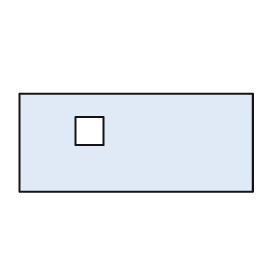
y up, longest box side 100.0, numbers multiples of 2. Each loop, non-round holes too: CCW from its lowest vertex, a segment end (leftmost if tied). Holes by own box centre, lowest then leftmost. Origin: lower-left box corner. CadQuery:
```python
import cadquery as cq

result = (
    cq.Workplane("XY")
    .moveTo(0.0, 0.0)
    .lineTo(100.0, 0.0)
    .lineTo(100.0, 42.0)
    .lineTo(0.0, 42.0)
    .close()
    .moveTo(24.0, 20.0)
    .lineTo(36.0, 20.0)
    .lineTo(36.0, 32.0)
    .lineTo(24.0, 32.0)
    .close()
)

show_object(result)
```